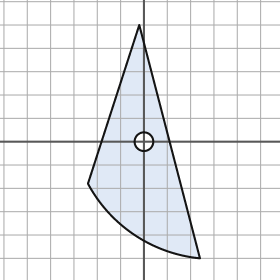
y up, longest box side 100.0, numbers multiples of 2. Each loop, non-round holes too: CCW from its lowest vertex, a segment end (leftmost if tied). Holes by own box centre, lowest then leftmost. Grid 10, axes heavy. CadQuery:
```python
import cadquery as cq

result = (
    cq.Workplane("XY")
    .moveTo(24.0, -50.0)
    .lineTo(-2.0, 50.0)
    .lineTo(-24.0, -18.0)
    .threePointArc((-4.0, -40.0), (24.0, -50.0))
    .close()
    .moveTo(0.0, 0.0)
    .circle(4.0)
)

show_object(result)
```